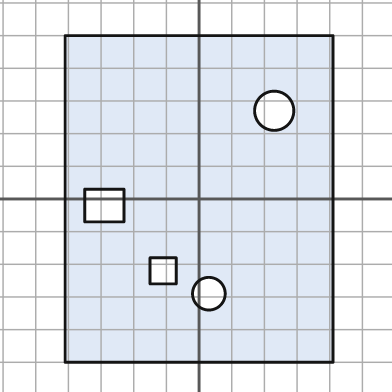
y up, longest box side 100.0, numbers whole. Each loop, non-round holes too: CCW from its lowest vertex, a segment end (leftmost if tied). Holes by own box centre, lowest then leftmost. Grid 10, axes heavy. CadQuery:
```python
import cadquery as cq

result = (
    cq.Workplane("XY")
    .moveTo(-41.0, -50.0)
    .lineTo(41.0, -50.0)
    .lineTo(41.0, 50.0)
    .lineTo(-41.0, 50.0)
    .close()
    .moveTo(3.0, -29.0)
    .circle(5.0)
    .moveTo(-15.0, -26.0)
    .lineTo(-7.0, -26.0)
    .lineTo(-7.0, -18.0)
    .lineTo(-15.0, -18.0)
    .close()
    .moveTo(-35.0, -7.0)
    .lineTo(-23.0, -7.0)
    .lineTo(-23.0, 3.0)
    .lineTo(-35.0, 3.0)
    .close()
    .moveTo(23.0, 27.0)
    .circle(6.0)
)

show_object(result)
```